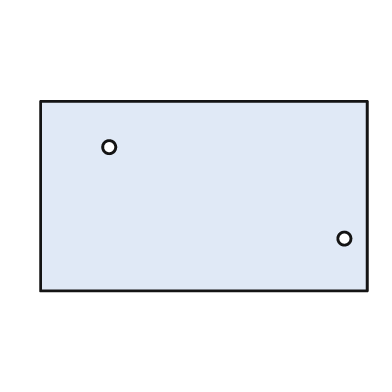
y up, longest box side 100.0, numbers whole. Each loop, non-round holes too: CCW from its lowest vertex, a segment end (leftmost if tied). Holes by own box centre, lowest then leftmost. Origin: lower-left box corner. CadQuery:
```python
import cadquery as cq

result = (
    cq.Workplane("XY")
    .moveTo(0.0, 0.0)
    .lineTo(100.0, 0.0)
    .lineTo(100.0, 58.0)
    .lineTo(0.0, 58.0)
    .close()
    .moveTo(93.0, 16.0)
    .circle(2.0)
    .moveTo(21.0, 44.0)
    .circle(2.0)
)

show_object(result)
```